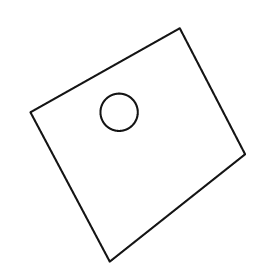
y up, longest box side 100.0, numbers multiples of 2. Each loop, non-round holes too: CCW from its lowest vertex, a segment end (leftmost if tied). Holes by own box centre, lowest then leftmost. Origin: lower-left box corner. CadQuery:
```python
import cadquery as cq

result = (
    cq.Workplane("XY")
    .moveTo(34.0, 0.0)
    .lineTo(92.0, 46.0)
    .lineTo(64.0, 100.0)
    .lineTo(0.0, 64.0)
    .close()
    .moveTo(38.0, 64.0)
    .circle(8.0)
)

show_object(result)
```